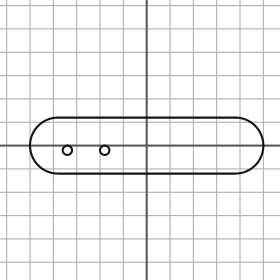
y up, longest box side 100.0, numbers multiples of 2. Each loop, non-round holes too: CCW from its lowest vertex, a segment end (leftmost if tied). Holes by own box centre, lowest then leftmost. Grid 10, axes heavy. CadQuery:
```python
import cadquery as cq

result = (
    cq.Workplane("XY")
    .moveTo(-38.0, -12.0)
    .lineTo(38.0, -12.0)
    .threePointArc((50.0, 0.0), (38.0, 12.0))
    .lineTo(-38.0, 12.0)
    .threePointArc((-50.0, 0.0), (-38.0, -12.0))
    .close()
    .moveTo(-34.0, -2.0)
    .circle(2.0)
    .moveTo(-18.0, -2.0)
    .circle(2.0)
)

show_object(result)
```